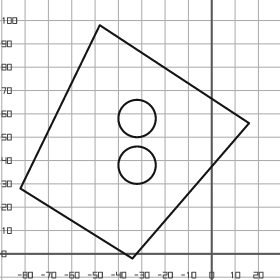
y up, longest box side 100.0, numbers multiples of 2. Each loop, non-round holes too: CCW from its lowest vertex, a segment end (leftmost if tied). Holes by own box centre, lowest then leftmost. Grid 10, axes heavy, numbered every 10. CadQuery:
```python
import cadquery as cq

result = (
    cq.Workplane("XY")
    .moveTo(-34.0, -2.0)
    .lineTo(16.0, 56.0)
    .lineTo(-48.0, 98.0)
    .lineTo(-82.0, 28.0)
    .close()
    .moveTo(-32.0, 38.0)
    .circle(8.0)
    .moveTo(-32.0, 58.0)
    .circle(8.0)
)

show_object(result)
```